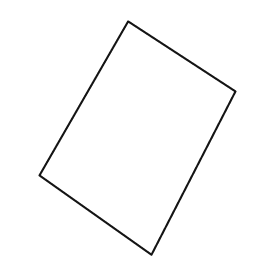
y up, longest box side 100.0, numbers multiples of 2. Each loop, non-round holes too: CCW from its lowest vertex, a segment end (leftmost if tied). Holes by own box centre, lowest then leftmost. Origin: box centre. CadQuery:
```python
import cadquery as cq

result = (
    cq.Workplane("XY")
    .moveTo(6.0, -50.0)
    .lineTo(42.0, 20.0)
    .lineTo(-4.0, 50.0)
    .lineTo(-42.0, -16.0)
    .close()
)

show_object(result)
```